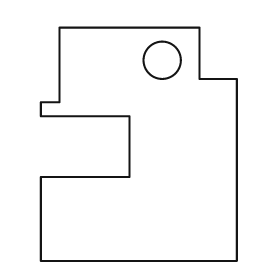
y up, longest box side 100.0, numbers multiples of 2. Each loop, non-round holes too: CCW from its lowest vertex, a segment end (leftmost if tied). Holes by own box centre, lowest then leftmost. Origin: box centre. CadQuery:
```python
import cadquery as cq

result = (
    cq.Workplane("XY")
    .moveTo(-42.0, -50.0)
    .lineTo(42.0, -50.0)
    .lineTo(42.0, 28.0)
    .lineTo(26.0, 28.0)
    .lineTo(26.0, 50.0)
    .lineTo(-34.0, 50.0)
    .lineTo(-34.0, 18.0)
    .lineTo(-42.0, 18.0)
    .lineTo(-42.0, 12.0)
    .lineTo(-4.0, 12.0)
    .lineTo(-4.0, -14.0)
    .lineTo(-42.0, -14.0)
    .close()
    .moveTo(10.0, 36.0)
    .circle(8.0)
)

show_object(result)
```